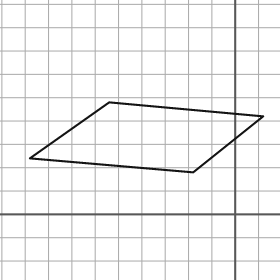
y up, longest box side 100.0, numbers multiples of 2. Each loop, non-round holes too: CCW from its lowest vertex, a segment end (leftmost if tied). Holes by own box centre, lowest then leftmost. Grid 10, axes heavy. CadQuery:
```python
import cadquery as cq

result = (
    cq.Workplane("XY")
    .moveTo(-18.0, 18.0)
    .lineTo(12.0, 42.0)
    .lineTo(-54.0, 48.0)
    .lineTo(-88.0, 24.0)
    .close()
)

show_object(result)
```